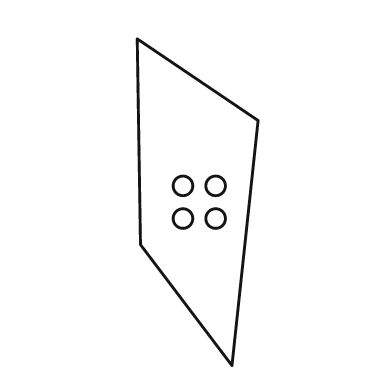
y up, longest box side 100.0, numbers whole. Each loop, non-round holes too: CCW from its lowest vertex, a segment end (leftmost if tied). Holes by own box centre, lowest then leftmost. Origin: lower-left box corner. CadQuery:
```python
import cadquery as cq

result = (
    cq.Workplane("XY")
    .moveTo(29.0, 0.0)
    .lineTo(37.0, 75.0)
    .lineTo(0.0, 100.0)
    .lineTo(1.0, 37.0)
    .close()
    .moveTo(14.0, 45.0)
    .circle(3.0)
    .moveTo(24.0, 45.0)
    .circle(3.0)
    .moveTo(14.0, 55.0)
    .circle(3.0)
    .moveTo(24.0, 55.0)
    .circle(3.0)
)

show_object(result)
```